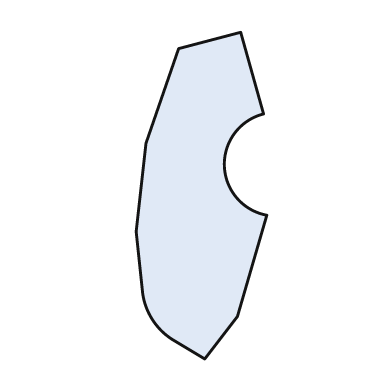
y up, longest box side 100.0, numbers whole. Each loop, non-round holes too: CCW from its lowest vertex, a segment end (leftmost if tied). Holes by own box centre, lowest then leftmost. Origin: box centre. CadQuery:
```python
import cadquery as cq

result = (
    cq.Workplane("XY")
    .moveTo(1.0, -50.0)
    .lineTo(11.0, -37.0)
    .lineTo(20.0, -6.0)
    .threePointArc((7.0, 9.0), (19.0, 25.0))
    .lineTo(12.0, 50.0)
    .lineTo(-7.0, 45.0)
    .lineTo(-17.0, 16.0)
    .lineTo(-20.0, -11.0)
    .lineTo(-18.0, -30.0)
    .threePointArc((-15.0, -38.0), (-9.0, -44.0))
    .close()
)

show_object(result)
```